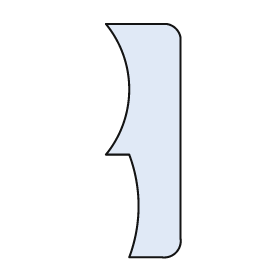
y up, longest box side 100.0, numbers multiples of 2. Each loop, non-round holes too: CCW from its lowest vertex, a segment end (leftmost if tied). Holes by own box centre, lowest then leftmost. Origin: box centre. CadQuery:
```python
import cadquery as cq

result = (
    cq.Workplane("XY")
    .moveTo(-6.0, -50.0)
    .lineTo(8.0, -50.0)
    .threePointArc((14.0, -48.0), (16.0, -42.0))
    .lineTo(16.0, 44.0)
    .threePointArc((14.0, 48.0), (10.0, 50.0))
    .lineTo(-16.0, 50.0)
    .threePointArc((-6.0, 22.0), (-16.0, -6.0))
    .lineTo(-6.0, -6.0)
    .threePointArc((-2.0, -28.0), (-6.0, -50.0))
    .close()
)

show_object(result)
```